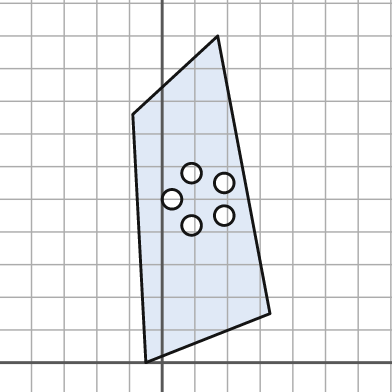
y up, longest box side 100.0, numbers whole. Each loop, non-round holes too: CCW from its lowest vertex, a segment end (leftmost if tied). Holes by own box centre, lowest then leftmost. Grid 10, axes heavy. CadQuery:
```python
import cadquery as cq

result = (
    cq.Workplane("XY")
    .moveTo(-5.0, 0.0)
    .lineTo(33.0, 15.0)
    .lineTo(17.0, 100.0)
    .lineTo(-9.0, 76.0)
    .close()
    .moveTo(9.0, 42.0)
    .circle(3.0)
    .moveTo(19.0, 45.0)
    .circle(3.0)
    .moveTo(3.0, 50.0)
    .circle(3.0)
    .moveTo(19.0, 55.0)
    .circle(3.0)
    .moveTo(9.0, 58.0)
    .circle(3.0)
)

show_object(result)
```